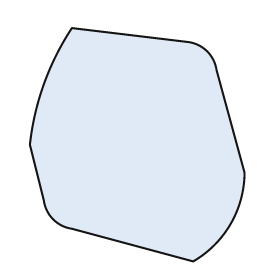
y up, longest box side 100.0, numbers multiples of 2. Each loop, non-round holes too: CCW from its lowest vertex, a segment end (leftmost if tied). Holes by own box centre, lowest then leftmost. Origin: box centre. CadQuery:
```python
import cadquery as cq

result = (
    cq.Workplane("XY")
    .moveTo(24.0, -50.0)
    .threePointArc((40.0, -34.0), (46.0, -12.0))
    .lineTo(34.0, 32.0)
    .threePointArc((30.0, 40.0), (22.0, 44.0))
    .lineTo(-28.0, 50.0)
    .threePointArc((-40.0, 26.0), (-46.0, 0.0))
    .lineTo(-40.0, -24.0)
    .threePointArc((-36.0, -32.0), (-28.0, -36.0))
    .close()
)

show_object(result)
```